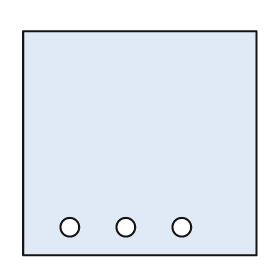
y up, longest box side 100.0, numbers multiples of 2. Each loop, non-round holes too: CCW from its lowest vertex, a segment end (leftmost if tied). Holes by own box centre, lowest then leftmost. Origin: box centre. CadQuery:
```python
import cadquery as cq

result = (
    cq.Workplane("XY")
    .moveTo(-50.0, -48.0)
    .lineTo(50.0, -48.0)
    .lineTo(50.0, 48.0)
    .lineTo(-50.0, 48.0)
    .close()
    .moveTo(-30.0, -36.0)
    .circle(4.0)
    .moveTo(-6.0, -36.0)
    .circle(4.0)
    .moveTo(18.0, -36.0)
    .circle(4.0)
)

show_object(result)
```